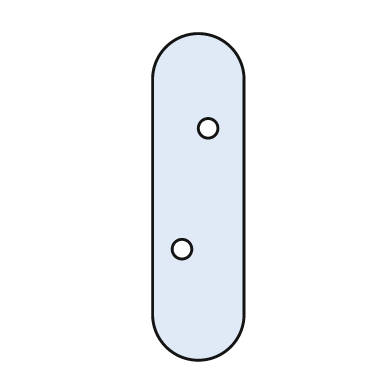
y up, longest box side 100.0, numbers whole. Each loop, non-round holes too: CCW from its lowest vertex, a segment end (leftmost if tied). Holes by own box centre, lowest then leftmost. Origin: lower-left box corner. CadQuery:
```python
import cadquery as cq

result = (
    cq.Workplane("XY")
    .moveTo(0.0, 14.0)
    .threePointArc((14.0, 0.0), (28.0, 14.0))
    .lineTo(28.0, 86.0)
    .threePointArc((14.0, 100.0), (0.0, 86.0))
    .close()
    .moveTo(9.0, 34.0)
    .circle(3.0)
    .moveTo(17.0, 71.0)
    .circle(3.0)
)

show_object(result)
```